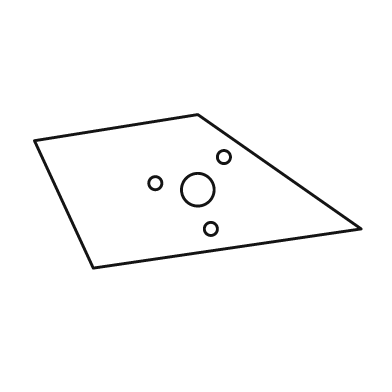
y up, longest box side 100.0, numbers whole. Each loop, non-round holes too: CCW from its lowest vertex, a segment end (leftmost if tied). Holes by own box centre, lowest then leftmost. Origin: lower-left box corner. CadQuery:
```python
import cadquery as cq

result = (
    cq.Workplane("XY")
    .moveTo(18.0, 0.0)
    .lineTo(100.0, 12.0)
    .lineTo(50.0, 47.0)
    .lineTo(0.0, 39.0)
    .close()
    .moveTo(54.0, 12.0)
    .circle(2.0)
    .moveTo(50.0, 24.0)
    .circle(5.0)
    .moveTo(37.0, 26.0)
    .circle(2.0)
    .moveTo(58.0, 34.0)
    .circle(2.0)
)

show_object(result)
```